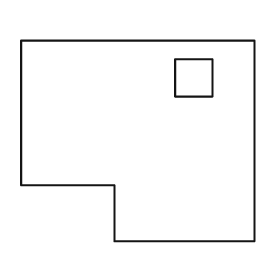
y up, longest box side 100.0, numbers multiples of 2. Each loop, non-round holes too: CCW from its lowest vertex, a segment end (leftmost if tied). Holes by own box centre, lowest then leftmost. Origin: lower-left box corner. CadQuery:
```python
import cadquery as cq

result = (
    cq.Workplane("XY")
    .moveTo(40.0, 0.0)
    .lineTo(100.0, 0.0)
    .lineTo(100.0, 86.0)
    .lineTo(0.0, 86.0)
    .lineTo(0.0, 24.0)
    .lineTo(40.0, 24.0)
    .close()
    .moveTo(66.0, 62.0)
    .lineTo(82.0, 62.0)
    .lineTo(82.0, 78.0)
    .lineTo(66.0, 78.0)
    .close()
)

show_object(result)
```